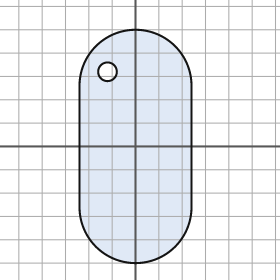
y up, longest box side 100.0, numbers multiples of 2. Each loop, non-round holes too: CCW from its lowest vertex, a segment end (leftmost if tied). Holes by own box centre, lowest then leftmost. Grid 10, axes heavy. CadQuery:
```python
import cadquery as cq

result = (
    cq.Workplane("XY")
    .moveTo(-24.0, -26.0)
    .threePointArc((0.0, -50.0), (24.0, -26.0))
    .lineTo(24.0, 26.0)
    .threePointArc((0.0, 50.0), (-24.0, 26.0))
    .close()
    .moveTo(-12.0, 32.0)
    .circle(4.0)
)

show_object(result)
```